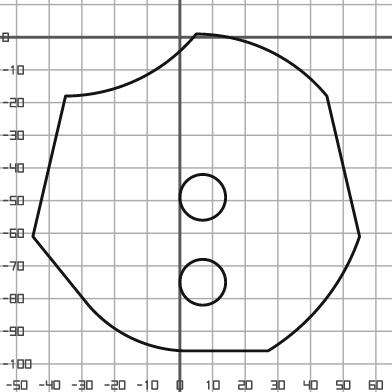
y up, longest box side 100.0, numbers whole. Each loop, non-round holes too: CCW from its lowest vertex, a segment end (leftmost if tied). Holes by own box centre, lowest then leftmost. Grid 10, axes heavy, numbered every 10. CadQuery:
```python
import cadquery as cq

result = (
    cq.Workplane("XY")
    .moveTo(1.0, -96.0)
    .lineTo(27.0, -96.0)
    .threePointArc((44.0, -81.0), (55.0, -61.0))
    .lineTo(45.0, -18.0)
    .threePointArc((27.0, -4.0), (5.0, 1.0))
    .threePointArc((-13.0, -13.0), (-35.0, -18.0))
    .lineTo(-45.0, -61.0)
    .lineTo(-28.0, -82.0)
    .threePointArc((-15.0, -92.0), (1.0, -96.0))
    .close()
    .moveTo(7.0, -75.0)
    .circle(7.0)
    .moveTo(7.0, -49.0)
    .circle(7.0)
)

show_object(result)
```